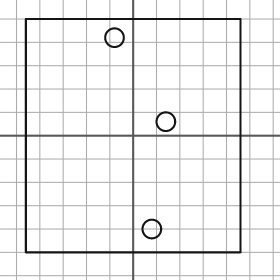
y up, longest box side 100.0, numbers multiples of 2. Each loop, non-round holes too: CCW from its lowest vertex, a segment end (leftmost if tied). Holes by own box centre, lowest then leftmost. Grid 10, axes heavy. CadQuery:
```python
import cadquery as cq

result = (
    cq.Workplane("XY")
    .moveTo(-46.0, -50.0)
    .lineTo(46.0, -50.0)
    .lineTo(46.0, 50.0)
    .lineTo(-46.0, 50.0)
    .close()
    .moveTo(8.0, -40.0)
    .circle(4.0)
    .moveTo(14.0, 6.0)
    .circle(4.0)
    .moveTo(-8.0, 42.0)
    .circle(4.0)
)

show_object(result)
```